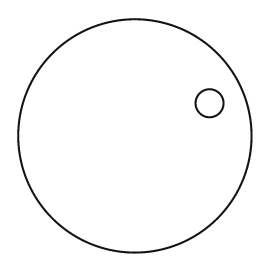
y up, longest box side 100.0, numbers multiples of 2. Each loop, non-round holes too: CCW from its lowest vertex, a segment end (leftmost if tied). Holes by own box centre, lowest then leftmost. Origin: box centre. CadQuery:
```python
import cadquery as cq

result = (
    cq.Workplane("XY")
    .moveTo(0.0, 0.0)
    .circle(50.0)
    .moveTo(32.0, 14.0)
    .circle(6.0)
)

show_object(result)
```